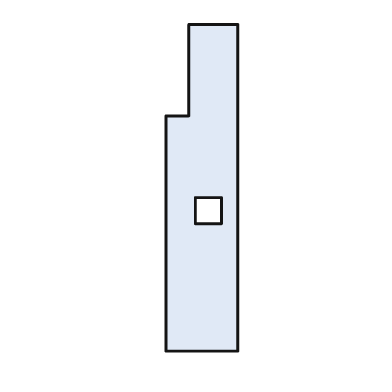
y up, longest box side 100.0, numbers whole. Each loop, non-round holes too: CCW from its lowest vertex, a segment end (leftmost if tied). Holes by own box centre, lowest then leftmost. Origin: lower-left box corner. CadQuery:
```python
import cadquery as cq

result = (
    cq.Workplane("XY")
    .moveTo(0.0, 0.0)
    .lineTo(22.0, 0.0)
    .lineTo(22.0, 100.0)
    .lineTo(7.0, 100.0)
    .lineTo(7.0, 72.0)
    .lineTo(0.0, 72.0)
    .close()
    .moveTo(9.0, 39.0)
    .lineTo(17.0, 39.0)
    .lineTo(17.0, 47.0)
    .lineTo(9.0, 47.0)
    .close()
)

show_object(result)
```